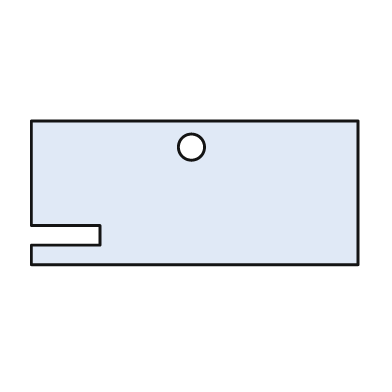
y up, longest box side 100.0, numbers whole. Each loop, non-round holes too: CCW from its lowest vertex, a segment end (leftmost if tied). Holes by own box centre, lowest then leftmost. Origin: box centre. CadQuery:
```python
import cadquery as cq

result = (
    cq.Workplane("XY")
    .moveTo(-50.0, -22.0)
    .lineTo(50.0, -22.0)
    .lineTo(50.0, 22.0)
    .lineTo(-50.0, 22.0)
    .lineTo(-50.0, -10.0)
    .lineTo(-29.0, -10.0)
    .lineTo(-29.0, -16.0)
    .lineTo(-50.0, -16.0)
    .close()
    .moveTo(-1.0, 14.0)
    .circle(4.0)
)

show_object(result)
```